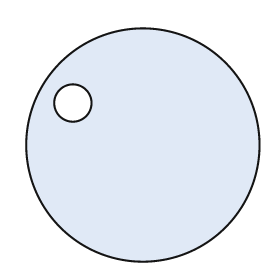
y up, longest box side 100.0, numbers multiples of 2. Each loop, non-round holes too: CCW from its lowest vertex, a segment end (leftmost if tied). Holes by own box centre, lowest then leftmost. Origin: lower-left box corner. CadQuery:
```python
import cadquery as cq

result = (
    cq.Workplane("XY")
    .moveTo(50.0, 50.0)
    .circle(50.0)
    .moveTo(20.0, 68.0)
    .circle(8.0)
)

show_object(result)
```